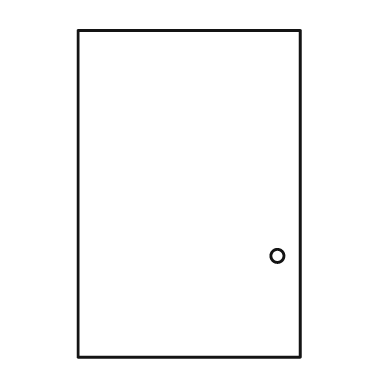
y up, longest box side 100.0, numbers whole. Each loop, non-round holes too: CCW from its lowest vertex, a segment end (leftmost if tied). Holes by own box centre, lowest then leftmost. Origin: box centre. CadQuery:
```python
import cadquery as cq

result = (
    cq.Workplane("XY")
    .moveTo(-34.0, -50.0)
    .lineTo(34.0, -50.0)
    .lineTo(34.0, 50.0)
    .lineTo(-34.0, 50.0)
    .close()
    .moveTo(27.0, -19.0)
    .circle(2.0)
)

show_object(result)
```